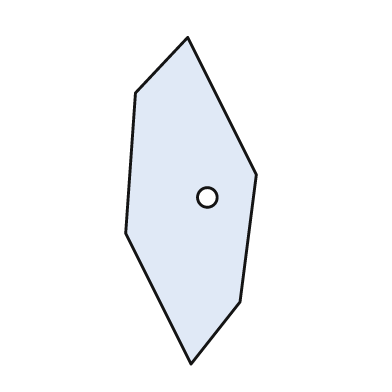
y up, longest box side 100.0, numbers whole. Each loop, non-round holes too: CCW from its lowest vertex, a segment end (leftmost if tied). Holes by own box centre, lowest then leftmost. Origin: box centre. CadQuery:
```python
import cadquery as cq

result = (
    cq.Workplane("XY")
    .moveTo(0.0, -50.0)
    .lineTo(15.0, -31.0)
    .lineTo(20.0, 8.0)
    .lineTo(-1.0, 50.0)
    .lineTo(-17.0, 33.0)
    .lineTo(-20.0, -10.0)
    .close()
    .moveTo(5.0, 1.0)
    .circle(3.0)
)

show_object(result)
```